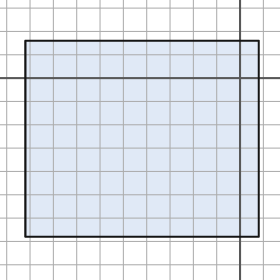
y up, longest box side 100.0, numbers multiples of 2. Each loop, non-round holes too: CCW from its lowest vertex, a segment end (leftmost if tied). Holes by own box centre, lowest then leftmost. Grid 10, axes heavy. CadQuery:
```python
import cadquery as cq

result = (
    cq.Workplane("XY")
    .moveTo(-92.0, -68.0)
    .lineTo(8.0, -68.0)
    .lineTo(8.0, 16.0)
    .lineTo(-92.0, 16.0)
    .close()
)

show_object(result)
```